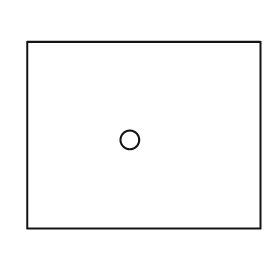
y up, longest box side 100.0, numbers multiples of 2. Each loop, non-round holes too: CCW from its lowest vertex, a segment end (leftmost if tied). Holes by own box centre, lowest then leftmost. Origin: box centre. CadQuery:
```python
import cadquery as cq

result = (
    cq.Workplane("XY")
    .moveTo(-50.0, -40.0)
    .lineTo(50.0, -40.0)
    .lineTo(50.0, 40.0)
    .lineTo(-50.0, 40.0)
    .close()
    .moveTo(-6.0, -2.0)
    .circle(4.0)
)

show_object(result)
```